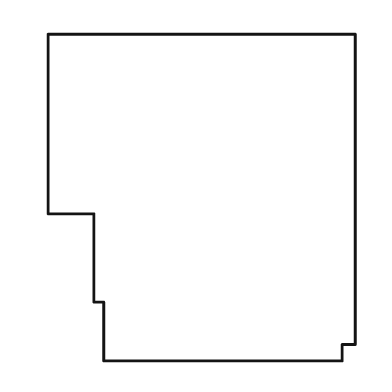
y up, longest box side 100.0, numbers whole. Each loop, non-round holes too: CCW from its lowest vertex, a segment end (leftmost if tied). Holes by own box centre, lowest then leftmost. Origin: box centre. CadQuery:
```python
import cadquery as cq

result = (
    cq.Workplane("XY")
    .moveTo(-30.0, -50.0)
    .lineTo(43.0, -50.0)
    .lineTo(43.0, -45.0)
    .lineTo(47.0, -45.0)
    .lineTo(47.0, 50.0)
    .lineTo(-47.0, 50.0)
    .lineTo(-47.0, -5.0)
    .lineTo(-33.0, -5.0)
    .lineTo(-33.0, -32.0)
    .lineTo(-30.0, -32.0)
    .close()
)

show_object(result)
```